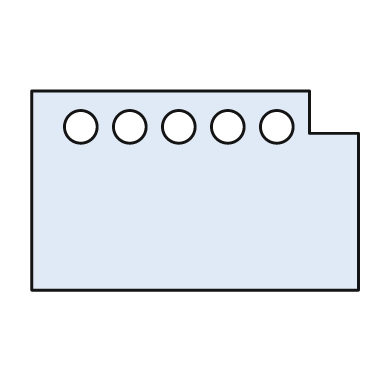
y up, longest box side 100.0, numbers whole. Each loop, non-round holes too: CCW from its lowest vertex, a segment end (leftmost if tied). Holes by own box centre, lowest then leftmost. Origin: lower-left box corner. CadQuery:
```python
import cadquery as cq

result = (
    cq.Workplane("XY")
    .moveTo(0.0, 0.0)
    .lineTo(100.0, 0.0)
    .lineTo(100.0, 48.0)
    .lineTo(85.0, 48.0)
    .lineTo(85.0, 61.0)
    .lineTo(0.0, 61.0)
    .close()
    .moveTo(15.0, 50.0)
    .circle(5.0)
    .moveTo(30.0, 50.0)
    .circle(5.0)
    .moveTo(45.0, 50.0)
    .circle(5.0)
    .moveTo(60.0, 50.0)
    .circle(5.0)
    .moveTo(75.0, 50.0)
    .circle(5.0)
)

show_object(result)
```